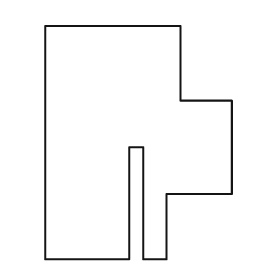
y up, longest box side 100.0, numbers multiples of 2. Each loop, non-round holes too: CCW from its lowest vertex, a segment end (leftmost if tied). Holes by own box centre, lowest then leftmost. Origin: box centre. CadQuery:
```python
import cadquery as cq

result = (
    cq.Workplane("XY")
    .moveTo(-40.0, -50.0)
    .lineTo(-4.0, -50.0)
    .lineTo(-4.0, -2.0)
    .lineTo(2.0, -2.0)
    .lineTo(2.0, -50.0)
    .lineTo(12.0, -50.0)
    .lineTo(12.0, -22.0)
    .lineTo(40.0, -22.0)
    .lineTo(40.0, 18.0)
    .lineTo(18.0, 18.0)
    .lineTo(18.0, 50.0)
    .lineTo(-40.0, 50.0)
    .close()
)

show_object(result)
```